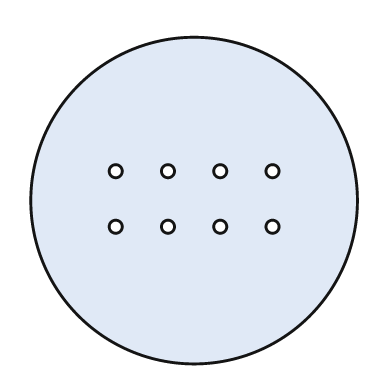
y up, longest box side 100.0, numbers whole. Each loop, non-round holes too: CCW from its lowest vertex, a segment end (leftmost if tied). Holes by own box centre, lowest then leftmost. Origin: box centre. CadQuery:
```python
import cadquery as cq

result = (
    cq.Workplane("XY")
    .moveTo(0.0, 0.0)
    .circle(50.0)
    .moveTo(-24.0, -8.0)
    .circle(2.0)
    .moveTo(-8.0, -8.0)
    .circle(2.0)
    .moveTo(8.0, -8.0)
    .circle(2.0)
    .moveTo(24.0, -8.0)
    .circle(2.0)
    .moveTo(-24.0, 9.0)
    .circle(2.0)
    .moveTo(-8.0, 9.0)
    .circle(2.0)
    .moveTo(8.0, 9.0)
    .circle(2.0)
    .moveTo(24.0, 9.0)
    .circle(2.0)
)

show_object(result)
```